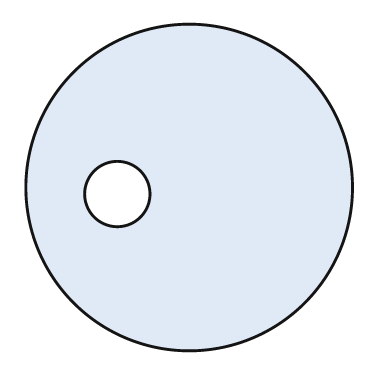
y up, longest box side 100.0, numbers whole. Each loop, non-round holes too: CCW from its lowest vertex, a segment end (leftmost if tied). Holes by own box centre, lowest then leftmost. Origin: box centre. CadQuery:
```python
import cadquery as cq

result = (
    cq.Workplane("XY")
    .moveTo(0.0, 0.0)
    .circle(50.0)
    .moveTo(-22.0, -2.0)
    .circle(10.0)
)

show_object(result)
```